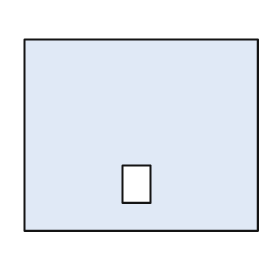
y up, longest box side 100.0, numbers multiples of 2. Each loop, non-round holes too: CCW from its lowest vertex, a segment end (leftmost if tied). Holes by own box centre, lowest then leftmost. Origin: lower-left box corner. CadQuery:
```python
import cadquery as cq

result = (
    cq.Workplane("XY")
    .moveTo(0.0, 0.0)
    .lineTo(100.0, 0.0)
    .lineTo(100.0, 82.0)
    .lineTo(0.0, 82.0)
    .close()
    .moveTo(42.0, 12.0)
    .lineTo(54.0, 12.0)
    .lineTo(54.0, 28.0)
    .lineTo(42.0, 28.0)
    .close()
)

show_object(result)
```